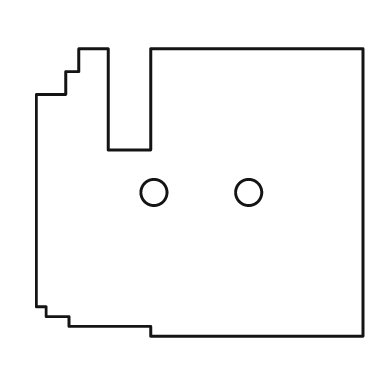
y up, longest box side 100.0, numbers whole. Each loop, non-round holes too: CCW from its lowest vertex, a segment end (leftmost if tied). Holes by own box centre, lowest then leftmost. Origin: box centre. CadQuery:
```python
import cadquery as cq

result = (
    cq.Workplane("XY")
    .moveTo(-15.0, -44.0)
    .lineTo(50.0, -44.0)
    .lineTo(50.0, 44.0)
    .lineTo(-15.0, 44.0)
    .lineTo(-15.0, 13.0)
    .lineTo(-28.0, 13.0)
    .lineTo(-28.0, 44.0)
    .lineTo(-37.0, 44.0)
    .lineTo(-37.0, 37.0)
    .lineTo(-41.0, 37.0)
    .lineTo(-41.0, 30.0)
    .lineTo(-50.0, 30.0)
    .lineTo(-50.0, -35.0)
    .lineTo(-47.0, -35.0)
    .lineTo(-47.0, -38.0)
    .lineTo(-40.0, -38.0)
    .lineTo(-40.0, -41.0)
    .lineTo(-15.0, -41.0)
    .close()
    .moveTo(-14.0, 0.0)
    .circle(4.0)
    .moveTo(15.0, 0.0)
    .circle(4.0)
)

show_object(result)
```